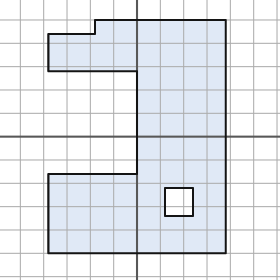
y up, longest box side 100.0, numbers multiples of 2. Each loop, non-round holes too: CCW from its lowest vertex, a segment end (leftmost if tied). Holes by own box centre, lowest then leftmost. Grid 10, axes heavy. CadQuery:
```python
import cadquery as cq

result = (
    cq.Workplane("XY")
    .moveTo(-38.0, -50.0)
    .lineTo(38.0, -50.0)
    .lineTo(38.0, 50.0)
    .lineTo(-18.0, 50.0)
    .lineTo(-18.0, 44.0)
    .lineTo(-38.0, 44.0)
    .lineTo(-38.0, 28.0)
    .lineTo(0.0, 28.0)
    .lineTo(0.0, -16.0)
    .lineTo(-38.0, -16.0)
    .close()
    .moveTo(12.0, -34.0)
    .lineTo(24.0, -34.0)
    .lineTo(24.0, -22.0)
    .lineTo(12.0, -22.0)
    .close()
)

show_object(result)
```